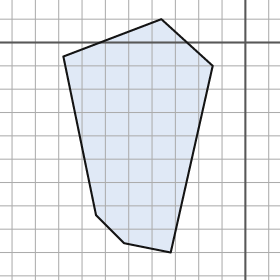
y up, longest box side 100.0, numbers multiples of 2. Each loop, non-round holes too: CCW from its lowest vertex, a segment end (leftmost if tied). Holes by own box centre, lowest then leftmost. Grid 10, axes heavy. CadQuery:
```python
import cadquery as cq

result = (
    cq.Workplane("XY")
    .moveTo(-32.0, -90.0)
    .lineTo(-14.0, -10.0)
    .lineTo(-36.0, 10.0)
    .lineTo(-78.0, -6.0)
    .lineTo(-64.0, -74.0)
    .lineTo(-52.0, -86.0)
    .close()
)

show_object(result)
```